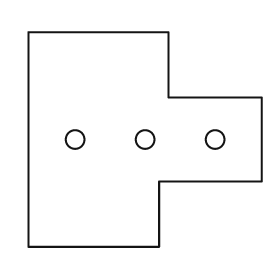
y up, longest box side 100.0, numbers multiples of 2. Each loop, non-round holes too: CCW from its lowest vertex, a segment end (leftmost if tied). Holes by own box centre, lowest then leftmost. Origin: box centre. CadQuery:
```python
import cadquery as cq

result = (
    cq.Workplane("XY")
    .moveTo(-50.0, -46.0)
    .lineTo(6.0, -46.0)
    .lineTo(6.0, -18.0)
    .lineTo(50.0, -18.0)
    .lineTo(50.0, 18.0)
    .lineTo(10.0, 18.0)
    .lineTo(10.0, 46.0)
    .lineTo(-50.0, 46.0)
    .close()
    .moveTo(-30.0, 0.0)
    .circle(4.0)
    .moveTo(0.0, 0.0)
    .circle(4.0)
    .moveTo(30.0, 0.0)
    .circle(4.0)
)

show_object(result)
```